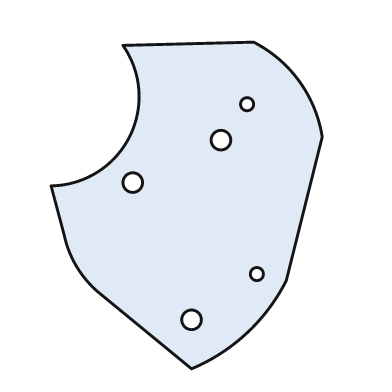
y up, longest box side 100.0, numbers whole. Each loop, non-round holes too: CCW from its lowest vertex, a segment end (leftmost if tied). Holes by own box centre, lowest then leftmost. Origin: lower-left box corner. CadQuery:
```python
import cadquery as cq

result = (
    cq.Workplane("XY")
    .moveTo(43.0, 0.0)
    .threePointArc((60.0, 11.0), (72.0, 27.0))
    .lineTo(83.0, 71.0)
    .threePointArc((76.0, 88.0), (62.0, 100.0))
    .lineTo(22.0, 99.0)
    .threePointArc((24.0, 71.0), (0.0, 56.0))
    .lineTo(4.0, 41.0)
    .threePointArc((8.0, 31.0), (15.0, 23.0))
    .close()
    .moveTo(43.0, 15.0)
    .circle(3.0)
    .moveTo(63.0, 29.0)
    .circle(2.0)
    .moveTo(25.0, 57.0)
    .circle(3.0)
    .moveTo(52.0, 70.0)
    .circle(3.0)
    .moveTo(60.0, 81.0)
    .circle(2.0)
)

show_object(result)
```